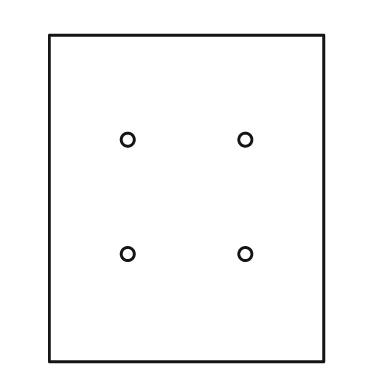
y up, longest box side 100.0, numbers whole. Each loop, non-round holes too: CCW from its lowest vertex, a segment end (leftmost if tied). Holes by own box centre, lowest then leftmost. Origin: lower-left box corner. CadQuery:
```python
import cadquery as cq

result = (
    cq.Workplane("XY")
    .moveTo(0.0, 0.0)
    .lineTo(84.0, 0.0)
    .lineTo(84.0, 100.0)
    .lineTo(0.0, 100.0)
    .close()
    .moveTo(24.0, 33.0)
    .circle(2.0)
    .moveTo(60.0, 33.0)
    .circle(2.0)
    .moveTo(24.0, 68.0)
    .circle(2.0)
    .moveTo(60.0, 68.0)
    .circle(2.0)
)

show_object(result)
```